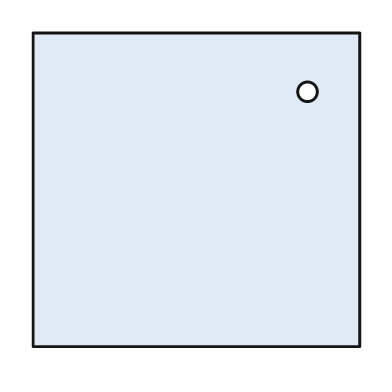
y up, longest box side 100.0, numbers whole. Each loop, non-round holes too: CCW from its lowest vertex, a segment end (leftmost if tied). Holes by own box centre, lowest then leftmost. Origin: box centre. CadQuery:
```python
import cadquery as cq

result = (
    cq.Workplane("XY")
    .moveTo(-50.0, -48.0)
    .lineTo(50.0, -48.0)
    .lineTo(50.0, 48.0)
    .lineTo(-50.0, 48.0)
    .close()
    .moveTo(34.0, 30.0)
    .circle(3.0)
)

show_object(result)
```